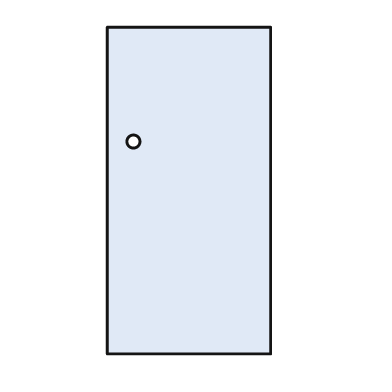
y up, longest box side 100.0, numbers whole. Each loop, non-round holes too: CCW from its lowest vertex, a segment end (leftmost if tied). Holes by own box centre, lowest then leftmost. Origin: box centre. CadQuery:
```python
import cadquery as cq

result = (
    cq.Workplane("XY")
    .moveTo(-25.0, -50.0)
    .lineTo(25.0, -50.0)
    .lineTo(25.0, 50.0)
    .lineTo(-25.0, 50.0)
    .close()
    .moveTo(-17.0, 15.0)
    .circle(2.0)
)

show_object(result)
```